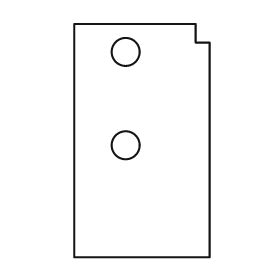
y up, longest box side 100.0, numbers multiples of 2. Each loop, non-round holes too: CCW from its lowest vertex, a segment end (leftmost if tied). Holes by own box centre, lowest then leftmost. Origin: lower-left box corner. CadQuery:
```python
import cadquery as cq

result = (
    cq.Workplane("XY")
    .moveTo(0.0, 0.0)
    .lineTo(58.0, 0.0)
    .lineTo(58.0, 92.0)
    .lineTo(52.0, 92.0)
    .lineTo(52.0, 100.0)
    .lineTo(0.0, 100.0)
    .close()
    .moveTo(22.0, 48.0)
    .circle(6.0)
    .moveTo(22.0, 88.0)
    .circle(6.0)
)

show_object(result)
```